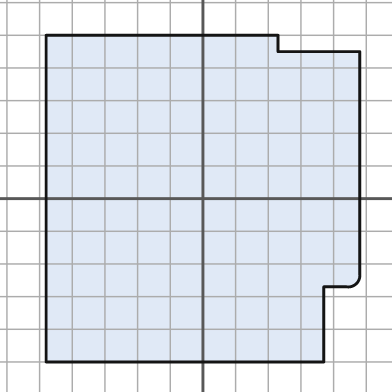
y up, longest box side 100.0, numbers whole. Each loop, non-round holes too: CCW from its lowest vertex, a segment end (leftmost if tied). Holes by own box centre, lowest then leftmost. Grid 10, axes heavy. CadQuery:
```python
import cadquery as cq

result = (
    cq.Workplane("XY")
    .moveTo(-48.0, -50.0)
    .lineTo(37.0, -50.0)
    .lineTo(37.0, -27.0)
    .lineTo(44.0, -27.0)
    .threePointArc((47.0, -26.0), (48.0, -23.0))
    .lineTo(48.0, 45.0)
    .lineTo(23.0, 45.0)
    .lineTo(23.0, 50.0)
    .lineTo(-48.0, 50.0)
    .close()
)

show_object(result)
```